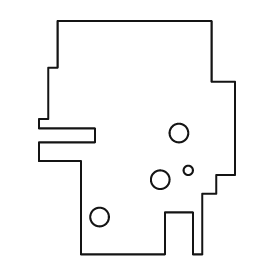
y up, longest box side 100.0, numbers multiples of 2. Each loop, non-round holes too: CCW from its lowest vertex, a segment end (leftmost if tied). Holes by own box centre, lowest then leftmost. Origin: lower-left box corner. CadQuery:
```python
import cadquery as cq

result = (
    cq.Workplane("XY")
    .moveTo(18.0, 0.0)
    .lineTo(54.0, 0.0)
    .lineTo(54.0, 18.0)
    .lineTo(66.0, 18.0)
    .lineTo(66.0, 0.0)
    .lineTo(70.0, 0.0)
    .lineTo(70.0, 26.0)
    .lineTo(76.0, 26.0)
    .lineTo(76.0, 34.0)
    .lineTo(84.0, 34.0)
    .lineTo(84.0, 74.0)
    .lineTo(74.0, 74.0)
    .lineTo(74.0, 100.0)
    .lineTo(8.0, 100.0)
    .lineTo(8.0, 80.0)
    .lineTo(4.0, 80.0)
    .lineTo(4.0, 58.0)
    .lineTo(0.0, 58.0)
    .lineTo(0.0, 54.0)
    .lineTo(24.0, 54.0)
    .lineTo(24.0, 48.0)
    .lineTo(0.0, 48.0)
    .lineTo(0.0, 40.0)
    .lineTo(18.0, 40.0)
    .close()
    .moveTo(26.0, 16.0)
    .circle(4.0)
    .moveTo(52.0, 32.0)
    .circle(4.0)
    .moveTo(64.0, 36.0)
    .circle(2.0)
    .moveTo(60.0, 52.0)
    .circle(4.0)
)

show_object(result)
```